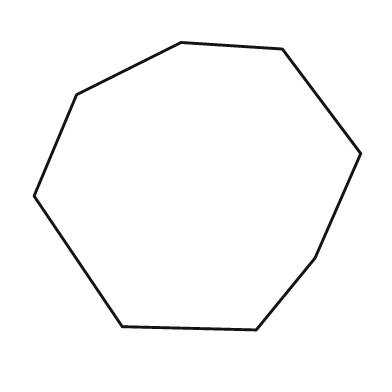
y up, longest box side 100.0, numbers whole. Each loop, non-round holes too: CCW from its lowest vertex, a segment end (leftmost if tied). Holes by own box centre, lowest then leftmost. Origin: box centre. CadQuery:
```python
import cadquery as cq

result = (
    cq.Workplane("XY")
    .moveTo(18.0, -44.0)
    .lineTo(36.0, -22.0)
    .lineTo(50.0, 10.0)
    .lineTo(26.0, 42.0)
    .lineTo(-5.0, 44.0)
    .lineTo(-37.0, 28.0)
    .lineTo(-50.0, -3.0)
    .lineTo(-23.0, -43.0)
    .close()
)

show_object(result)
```